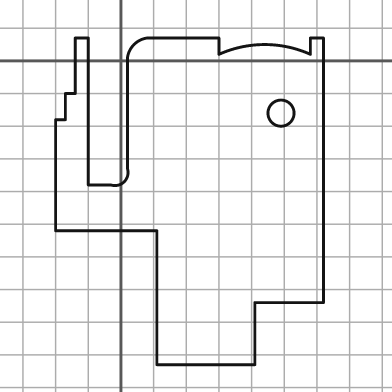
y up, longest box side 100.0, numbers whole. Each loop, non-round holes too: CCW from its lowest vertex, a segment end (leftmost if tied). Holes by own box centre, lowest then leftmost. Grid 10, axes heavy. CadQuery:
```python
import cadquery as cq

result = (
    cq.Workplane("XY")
    .moveTo(11.0, -93.0)
    .lineTo(41.0, -93.0)
    .lineTo(41.0, -74.0)
    .lineTo(62.0, -74.0)
    .lineTo(62.0, 7.0)
    .lineTo(58.0, 7.0)
    .lineTo(58.0, 2.0)
    .threePointArc((44.0, 5.0), (30.0, 2.0))
    .lineTo(30.0, 7.0)
    .lineTo(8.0, 7.0)
    .threePointArc((4.0, 5.0), (2.0, 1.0))
    .lineTo(2.0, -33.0)
    .threePointArc((1.0, -37.0), (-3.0, -38.0))
    .lineTo(-10.0, -38.0)
    .lineTo(-10.0, 7.0)
    .lineTo(-14.0, 7.0)
    .lineTo(-14.0, -10.0)
    .lineTo(-17.0, -10.0)
    .lineTo(-17.0, -18.0)
    .lineTo(-20.0, -18.0)
    .lineTo(-20.0, -52.0)
    .lineTo(11.0, -52.0)
    .close()
    .moveTo(49.0, -16.0)
    .circle(4.0)
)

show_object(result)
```